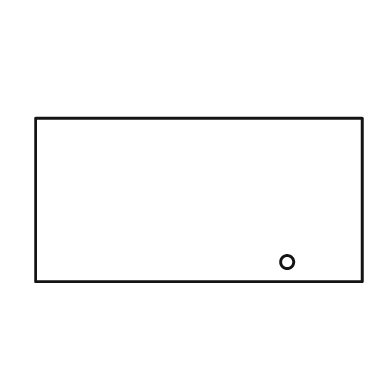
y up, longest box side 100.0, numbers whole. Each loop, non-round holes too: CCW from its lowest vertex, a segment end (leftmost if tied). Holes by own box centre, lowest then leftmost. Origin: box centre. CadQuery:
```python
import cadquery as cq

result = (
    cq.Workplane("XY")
    .moveTo(-50.0, -25.0)
    .lineTo(50.0, -25.0)
    .lineTo(50.0, 25.0)
    .lineTo(-50.0, 25.0)
    .close()
    .moveTo(27.0, -19.0)
    .circle(2.0)
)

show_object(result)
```